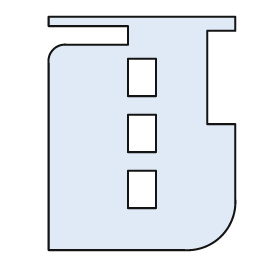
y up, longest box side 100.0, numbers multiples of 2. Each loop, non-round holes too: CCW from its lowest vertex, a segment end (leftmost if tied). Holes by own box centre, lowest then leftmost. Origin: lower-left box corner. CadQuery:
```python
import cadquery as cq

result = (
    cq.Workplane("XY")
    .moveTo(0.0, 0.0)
    .lineTo(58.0, 0.0)
    .threePointArc((74.0, 6.0), (80.0, 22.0))
    .lineTo(80.0, 54.0)
    .lineTo(68.0, 54.0)
    .lineTo(68.0, 94.0)
    .lineTo(80.0, 94.0)
    .lineTo(80.0, 100.0)
    .lineTo(0.0, 100.0)
    .lineTo(0.0, 96.0)
    .lineTo(34.0, 96.0)
    .lineTo(34.0, 88.0)
    .lineTo(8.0, 88.0)
    .threePointArc((2.0, 86.0), (0.0, 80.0))
    .close()
    .moveTo(34.0, 18.0)
    .lineTo(46.0, 18.0)
    .lineTo(46.0, 34.0)
    .lineTo(34.0, 34.0)
    .close()
    .moveTo(34.0, 42.0)
    .lineTo(46.0, 42.0)
    .lineTo(46.0, 58.0)
    .lineTo(34.0, 58.0)
    .close()
    .moveTo(34.0, 66.0)
    .lineTo(46.0, 66.0)
    .lineTo(46.0, 82.0)
    .lineTo(34.0, 82.0)
    .close()
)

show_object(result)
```